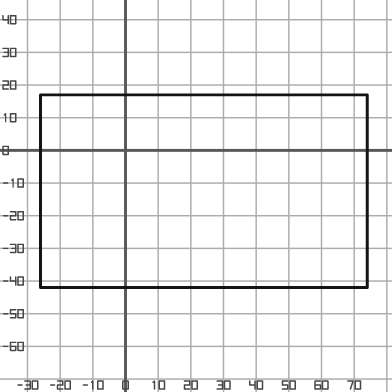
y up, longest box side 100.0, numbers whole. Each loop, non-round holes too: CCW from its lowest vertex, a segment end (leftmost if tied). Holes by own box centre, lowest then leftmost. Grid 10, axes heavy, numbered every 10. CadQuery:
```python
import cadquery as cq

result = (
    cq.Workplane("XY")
    .moveTo(-26.0, -42.0)
    .lineTo(74.0, -42.0)
    .lineTo(74.0, 17.0)
    .lineTo(-26.0, 17.0)
    .close()
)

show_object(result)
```